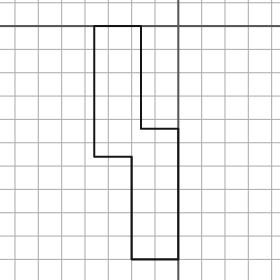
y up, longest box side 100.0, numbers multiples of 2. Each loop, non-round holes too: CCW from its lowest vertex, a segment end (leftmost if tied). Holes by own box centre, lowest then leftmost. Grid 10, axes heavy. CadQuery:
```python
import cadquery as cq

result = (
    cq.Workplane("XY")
    .moveTo(-20.0, -100.0)
    .lineTo(0.0, -100.0)
    .lineTo(0.0, -44.0)
    .lineTo(-16.0, -44.0)
    .lineTo(-16.0, 0.0)
    .lineTo(-36.0, 0.0)
    .lineTo(-36.0, -56.0)
    .lineTo(-20.0, -56.0)
    .close()
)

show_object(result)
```